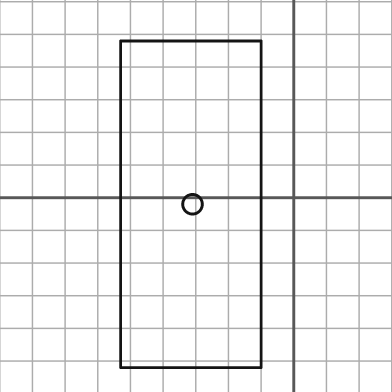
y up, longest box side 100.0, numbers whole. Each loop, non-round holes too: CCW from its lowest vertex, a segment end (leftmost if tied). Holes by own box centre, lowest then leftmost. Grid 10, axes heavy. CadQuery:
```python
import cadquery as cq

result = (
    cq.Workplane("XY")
    .moveTo(-53.0, -52.0)
    .lineTo(-10.0, -52.0)
    .lineTo(-10.0, 48.0)
    .lineTo(-53.0, 48.0)
    .close()
    .moveTo(-31.0, -2.0)
    .circle(3.0)
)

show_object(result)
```